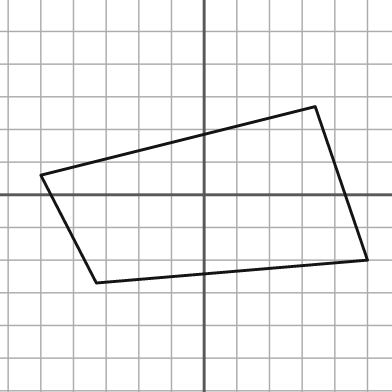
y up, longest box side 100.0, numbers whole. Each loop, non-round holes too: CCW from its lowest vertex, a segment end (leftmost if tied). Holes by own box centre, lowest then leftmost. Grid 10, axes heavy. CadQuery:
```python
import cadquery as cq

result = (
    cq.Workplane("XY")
    .moveTo(-33.0, -27.0)
    .lineTo(50.0, -20.0)
    .lineTo(34.0, 27.0)
    .lineTo(-50.0, 6.0)
    .close()
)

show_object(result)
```